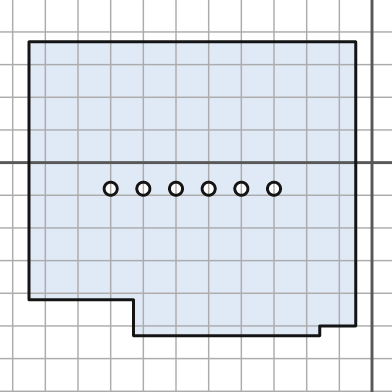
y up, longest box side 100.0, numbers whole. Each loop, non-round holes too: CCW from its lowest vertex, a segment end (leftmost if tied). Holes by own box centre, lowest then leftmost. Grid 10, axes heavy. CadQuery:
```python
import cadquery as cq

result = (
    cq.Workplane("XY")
    .moveTo(-73.0, -53.0)
    .lineTo(-16.0, -53.0)
    .lineTo(-16.0, -50.0)
    .lineTo(-5.0, -50.0)
    .lineTo(-5.0, 37.0)
    .lineTo(-105.0, 37.0)
    .lineTo(-105.0, -42.0)
    .lineTo(-73.0, -42.0)
    .close()
    .moveTo(-80.0, -8.0)
    .circle(2.0)
    .moveTo(-70.0, -8.0)
    .circle(2.0)
    .moveTo(-60.0, -8.0)
    .circle(2.0)
    .moveTo(-50.0, -8.0)
    .circle(2.0)
    .moveTo(-40.0, -8.0)
    .circle(2.0)
    .moveTo(-30.0, -8.0)
    .circle(2.0)
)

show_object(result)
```